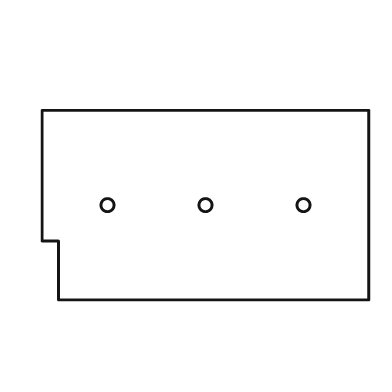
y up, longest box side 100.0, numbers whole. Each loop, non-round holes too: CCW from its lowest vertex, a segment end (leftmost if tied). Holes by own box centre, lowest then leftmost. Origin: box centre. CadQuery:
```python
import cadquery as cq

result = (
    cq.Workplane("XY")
    .moveTo(-45.0, -29.0)
    .lineTo(50.0, -29.0)
    .lineTo(50.0, 29.0)
    .lineTo(-50.0, 29.0)
    .lineTo(-50.0, -11.0)
    .lineTo(-45.0, -11.0)
    .close()
    .moveTo(-30.0, 0.0)
    .circle(2.0)
    .moveTo(0.0, 0.0)
    .circle(2.0)
    .moveTo(30.0, 0.0)
    .circle(2.0)
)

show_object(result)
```